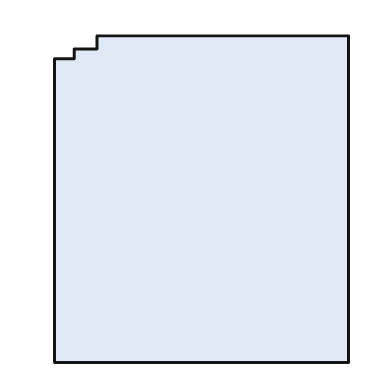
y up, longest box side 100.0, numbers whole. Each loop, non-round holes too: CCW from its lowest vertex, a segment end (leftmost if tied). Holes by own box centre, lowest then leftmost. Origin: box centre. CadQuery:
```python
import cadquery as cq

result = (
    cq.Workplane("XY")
    .moveTo(-45.0, -50.0)
    .lineTo(45.0, -50.0)
    .lineTo(45.0, 50.0)
    .lineTo(-32.0, 50.0)
    .lineTo(-32.0, 46.0)
    .lineTo(-39.0, 46.0)
    .lineTo(-39.0, 43.0)
    .lineTo(-45.0, 43.0)
    .close()
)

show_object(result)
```